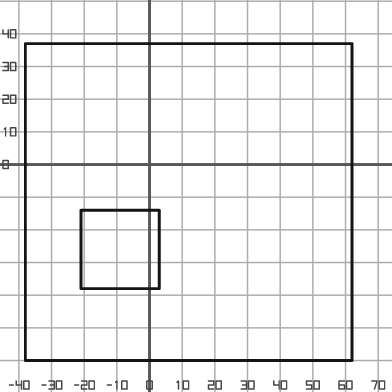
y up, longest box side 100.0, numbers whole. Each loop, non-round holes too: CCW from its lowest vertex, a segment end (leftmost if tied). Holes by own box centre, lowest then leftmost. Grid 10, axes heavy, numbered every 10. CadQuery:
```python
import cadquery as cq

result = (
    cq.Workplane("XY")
    .moveTo(-38.0, -60.0)
    .lineTo(62.0, -60.0)
    .lineTo(62.0, 37.0)
    .lineTo(-38.0, 37.0)
    .close()
    .moveTo(-21.0, -38.0)
    .lineTo(3.0, -38.0)
    .lineTo(3.0, -14.0)
    .lineTo(-21.0, -14.0)
    .close()
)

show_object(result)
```